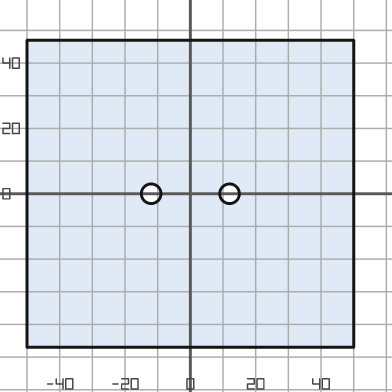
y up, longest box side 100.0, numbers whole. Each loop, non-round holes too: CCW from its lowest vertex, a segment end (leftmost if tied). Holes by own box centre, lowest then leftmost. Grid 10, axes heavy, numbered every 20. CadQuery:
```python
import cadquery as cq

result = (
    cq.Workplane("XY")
    .moveTo(-50.0, -47.0)
    .lineTo(50.0, -47.0)
    .lineTo(50.0, 47.0)
    .lineTo(-50.0, 47.0)
    .close()
    .moveTo(-12.0, 0.0)
    .circle(3.0)
    .moveTo(12.0, 0.0)
    .circle(3.0)
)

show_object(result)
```